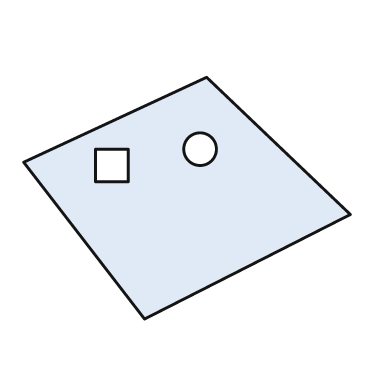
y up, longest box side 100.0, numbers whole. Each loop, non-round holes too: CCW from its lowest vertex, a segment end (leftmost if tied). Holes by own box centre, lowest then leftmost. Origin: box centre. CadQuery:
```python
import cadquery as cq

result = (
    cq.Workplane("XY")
    .moveTo(-13.0, -37.0)
    .lineTo(50.0, -5.0)
    .lineTo(6.0, 37.0)
    .lineTo(-50.0, 11.0)
    .close()
    .moveTo(-28.0, 5.0)
    .lineTo(-18.0, 5.0)
    .lineTo(-18.0, 15.0)
    .lineTo(-28.0, 15.0)
    .close()
    .moveTo(4.0, 15.0)
    .circle(5.0)
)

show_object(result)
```